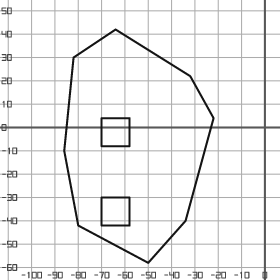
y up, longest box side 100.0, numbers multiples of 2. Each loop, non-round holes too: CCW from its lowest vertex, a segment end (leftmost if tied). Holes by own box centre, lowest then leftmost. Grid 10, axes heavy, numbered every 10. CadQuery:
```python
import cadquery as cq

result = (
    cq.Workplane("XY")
    .moveTo(-50.0, -58.0)
    .lineTo(-34.0, -40.0)
    .lineTo(-22.0, 4.0)
    .lineTo(-32.0, 22.0)
    .lineTo(-64.0, 42.0)
    .lineTo(-82.0, 30.0)
    .lineTo(-86.0, -10.0)
    .lineTo(-80.0, -42.0)
    .close()
    .moveTo(-70.0, -42.0)
    .lineTo(-58.0, -42.0)
    .lineTo(-58.0, -30.0)
    .lineTo(-70.0, -30.0)
    .close()
    .moveTo(-70.0, -8.0)
    .lineTo(-58.0, -8.0)
    .lineTo(-58.0, 4.0)
    .lineTo(-70.0, 4.0)
    .close()
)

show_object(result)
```